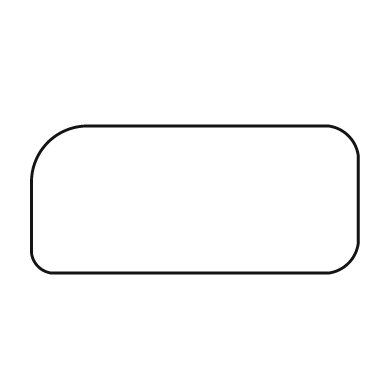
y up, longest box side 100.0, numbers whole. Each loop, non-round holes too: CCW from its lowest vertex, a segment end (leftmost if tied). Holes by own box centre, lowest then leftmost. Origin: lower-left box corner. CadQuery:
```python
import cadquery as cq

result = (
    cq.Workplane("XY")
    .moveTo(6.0, 0.0)
    .lineTo(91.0, 0.0)
    .threePointArc((97.0, 3.0), (100.0, 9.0))
    .lineTo(100.0, 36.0)
    .threePointArc((97.0, 42.0), (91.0, 45.0))
    .lineTo(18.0, 45.0)
    .threePointArc((5.0, 40.0), (0.0, 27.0))
    .lineTo(0.0, 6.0)
    .threePointArc((2.0, 2.0), (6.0, 0.0))
    .close()
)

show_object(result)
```